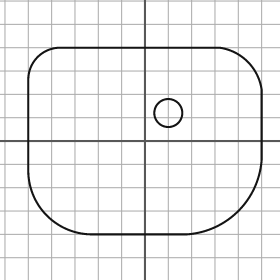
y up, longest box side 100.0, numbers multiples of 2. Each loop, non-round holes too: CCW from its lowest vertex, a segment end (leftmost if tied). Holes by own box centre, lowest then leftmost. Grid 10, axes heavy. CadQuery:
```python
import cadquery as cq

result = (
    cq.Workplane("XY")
    .moveTo(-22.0, -40.0)
    .lineTo(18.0, -40.0)
    .threePointArc((40.0, -30.0), (50.0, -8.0))
    .lineTo(50.0, 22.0)
    .threePointArc((44.0, 34.0), (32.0, 40.0))
    .lineTo(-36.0, 40.0)
    .threePointArc((-46.0, 36.0), (-50.0, 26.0))
    .lineTo(-50.0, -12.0)
    .threePointArc((-42.0, -32.0), (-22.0, -40.0))
    .close()
    .moveTo(10.0, 12.0)
    .circle(6.0)
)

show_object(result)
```